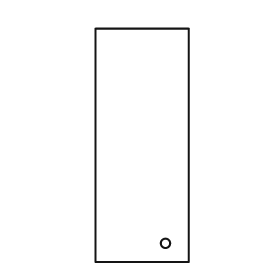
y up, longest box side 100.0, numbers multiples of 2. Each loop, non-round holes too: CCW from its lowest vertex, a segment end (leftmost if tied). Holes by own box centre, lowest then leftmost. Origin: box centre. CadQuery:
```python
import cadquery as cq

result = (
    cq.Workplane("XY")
    .moveTo(-20.0, -50.0)
    .lineTo(20.0, -50.0)
    .lineTo(20.0, 50.0)
    .lineTo(-20.0, 50.0)
    .close()
    .moveTo(10.0, -42.0)
    .circle(2.0)
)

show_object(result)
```